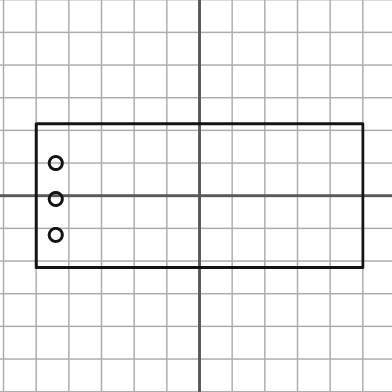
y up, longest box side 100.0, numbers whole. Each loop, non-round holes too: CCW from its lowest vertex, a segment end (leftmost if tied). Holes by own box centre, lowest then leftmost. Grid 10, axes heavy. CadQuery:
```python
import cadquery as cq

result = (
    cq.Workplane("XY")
    .moveTo(-50.0, -22.0)
    .lineTo(50.0, -22.0)
    .lineTo(50.0, 22.0)
    .lineTo(-50.0, 22.0)
    .close()
    .moveTo(-44.0, -12.0)
    .circle(2.0)
    .moveTo(-44.0, -1.0)
    .circle(2.0)
    .moveTo(-44.0, 10.0)
    .circle(2.0)
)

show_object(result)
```